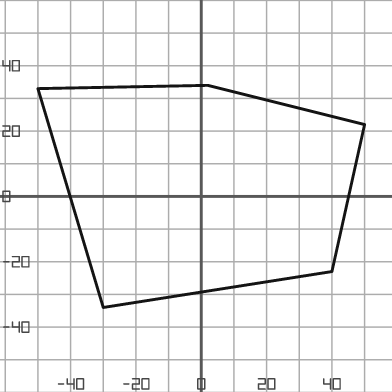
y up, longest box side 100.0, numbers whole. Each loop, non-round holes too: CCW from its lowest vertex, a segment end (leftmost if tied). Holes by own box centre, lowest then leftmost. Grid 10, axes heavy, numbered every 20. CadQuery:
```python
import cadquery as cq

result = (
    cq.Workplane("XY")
    .moveTo(-30.0, -34.0)
    .lineTo(40.0, -23.0)
    .lineTo(50.0, 22.0)
    .lineTo(2.0, 34.0)
    .lineTo(-50.0, 33.0)
    .close()
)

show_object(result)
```